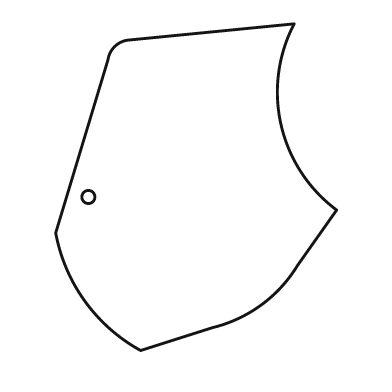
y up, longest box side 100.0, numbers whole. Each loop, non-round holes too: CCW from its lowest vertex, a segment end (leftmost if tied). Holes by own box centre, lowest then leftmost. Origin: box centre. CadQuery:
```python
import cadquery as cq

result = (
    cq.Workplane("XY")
    .moveTo(-17.0, -50.0)
    .lineTo(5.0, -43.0)
    .threePointArc((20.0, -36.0), (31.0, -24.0))
    .lineTo(43.0, -7.0)
    .threePointArc((26.0, 19.0), (30.0, 50.0))
    .lineTo(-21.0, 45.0)
    .threePointArc((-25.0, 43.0), (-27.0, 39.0))
    .lineTo(-43.0, -14.0)
    .threePointArc((-34.0, -35.0), (-17.0, -50.0))
    .close()
    .moveTo(-33.0, -3.0)
    .circle(2.0)
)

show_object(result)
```